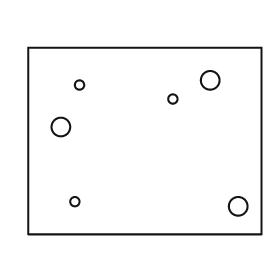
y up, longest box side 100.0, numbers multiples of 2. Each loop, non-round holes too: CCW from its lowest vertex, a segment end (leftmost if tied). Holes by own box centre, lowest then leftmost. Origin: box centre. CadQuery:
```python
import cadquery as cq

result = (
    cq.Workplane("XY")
    .moveTo(-50.0, -40.0)
    .lineTo(50.0, -40.0)
    .lineTo(50.0, 40.0)
    .lineTo(-50.0, 40.0)
    .close()
    .moveTo(40.0, -28.0)
    .circle(4.0)
    .moveTo(-30.0, -26.0)
    .circle(2.0)
    .moveTo(-36.0, 6.0)
    .circle(4.0)
    .moveTo(12.0, 18.0)
    .circle(2.0)
    .moveTo(-28.0, 24.0)
    .circle(2.0)
    .moveTo(28.0, 26.0)
    .circle(4.0)
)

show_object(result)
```